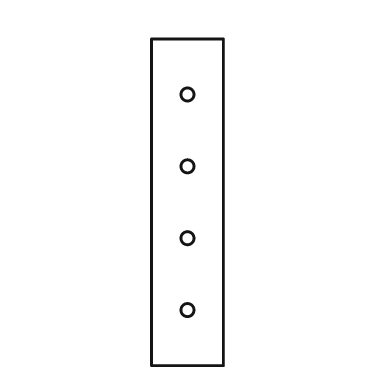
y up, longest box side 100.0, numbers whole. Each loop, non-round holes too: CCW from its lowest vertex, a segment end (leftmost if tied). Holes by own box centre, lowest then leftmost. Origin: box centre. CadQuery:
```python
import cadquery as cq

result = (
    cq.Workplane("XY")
    .moveTo(-11.0, -50.0)
    .lineTo(11.0, -50.0)
    .lineTo(11.0, 50.0)
    .lineTo(-11.0, 50.0)
    .close()
    .moveTo(0.0, -33.0)
    .circle(2.0)
    .moveTo(0.0, -11.0)
    .circle(2.0)
    .moveTo(0.0, 11.0)
    .circle(2.0)
    .moveTo(0.0, 33.0)
    .circle(2.0)
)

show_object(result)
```